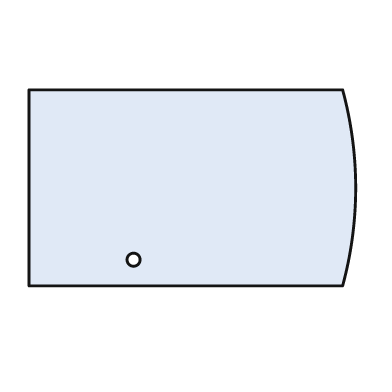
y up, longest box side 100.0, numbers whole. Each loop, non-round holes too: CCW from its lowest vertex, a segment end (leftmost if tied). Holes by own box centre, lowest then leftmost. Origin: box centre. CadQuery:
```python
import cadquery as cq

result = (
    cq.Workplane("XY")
    .moveTo(-50.0, -30.0)
    .lineTo(46.0, -30.0)
    .threePointArc((50.0, 0.0), (46.0, 30.0))
    .lineTo(-50.0, 30.0)
    .close()
    .moveTo(-18.0, -22.0)
    .circle(2.0)
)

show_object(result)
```